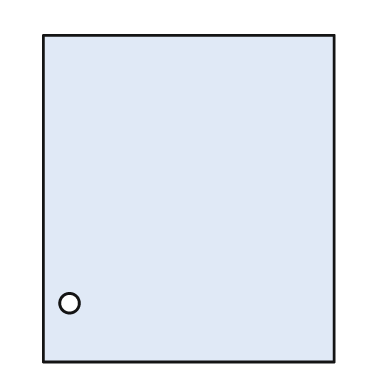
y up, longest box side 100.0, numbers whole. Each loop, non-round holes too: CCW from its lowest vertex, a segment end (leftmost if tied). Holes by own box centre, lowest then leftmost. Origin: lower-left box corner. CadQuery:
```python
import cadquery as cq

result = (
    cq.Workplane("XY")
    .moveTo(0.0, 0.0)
    .lineTo(89.0, 0.0)
    .lineTo(89.0, 100.0)
    .lineTo(0.0, 100.0)
    .close()
    .moveTo(8.0, 18.0)
    .circle(3.0)
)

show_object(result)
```